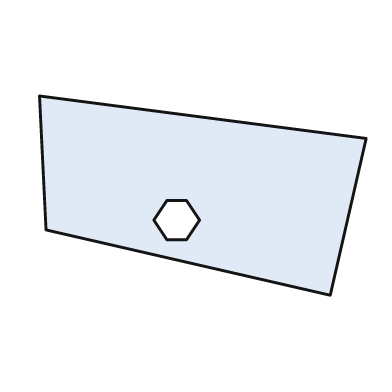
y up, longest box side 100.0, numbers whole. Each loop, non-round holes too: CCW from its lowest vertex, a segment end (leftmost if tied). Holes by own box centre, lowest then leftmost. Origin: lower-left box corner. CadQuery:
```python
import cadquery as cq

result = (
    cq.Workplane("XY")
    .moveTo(89.0, 0.0)
    .lineTo(100.0, 48.0)
    .lineTo(0.0, 61.0)
    .lineTo(2.0, 20.0)
    .close()
    .moveTo(39.0, 17.0)
    .lineTo(45.0, 17.0)
    .lineTo(49.0, 23.0)
    .lineTo(45.0, 29.0)
    .lineTo(39.0, 29.0)
    .lineTo(35.0, 23.0)
    .close()
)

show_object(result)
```